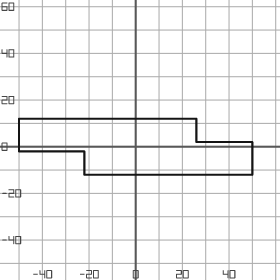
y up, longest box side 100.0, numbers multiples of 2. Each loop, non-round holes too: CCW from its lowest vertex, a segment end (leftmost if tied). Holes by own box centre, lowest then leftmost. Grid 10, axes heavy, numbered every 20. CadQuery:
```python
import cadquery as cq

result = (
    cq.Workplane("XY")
    .moveTo(-22.0, -12.0)
    .lineTo(50.0, -12.0)
    .lineTo(50.0, 2.0)
    .lineTo(26.0, 2.0)
    .lineTo(26.0, 12.0)
    .lineTo(-50.0, 12.0)
    .lineTo(-50.0, -2.0)
    .lineTo(-22.0, -2.0)
    .close()
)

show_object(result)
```